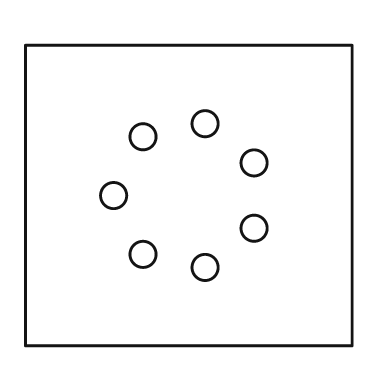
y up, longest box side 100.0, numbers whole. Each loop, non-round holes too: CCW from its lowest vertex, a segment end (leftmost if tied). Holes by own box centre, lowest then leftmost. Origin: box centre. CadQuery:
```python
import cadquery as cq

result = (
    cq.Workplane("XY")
    .moveTo(-50.0, -46.0)
    .lineTo(50.0, -46.0)
    .lineTo(50.0, 46.0)
    .lineTo(-50.0, 46.0)
    .close()
    .moveTo(5.0, -22.0)
    .circle(4.0)
    .moveTo(-14.0, -18.0)
    .circle(4.0)
    .moveTo(20.0, -10.0)
    .circle(4.0)
    .moveTo(-23.0, 0.0)
    .circle(4.0)
    .moveTo(20.0, 10.0)
    .circle(4.0)
    .moveTo(-14.0, 18.0)
    .circle(4.0)
    .moveTo(5.0, 22.0)
    .circle(4.0)
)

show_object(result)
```